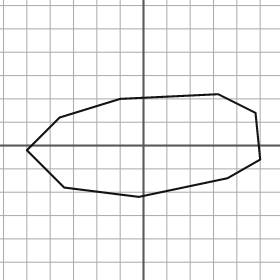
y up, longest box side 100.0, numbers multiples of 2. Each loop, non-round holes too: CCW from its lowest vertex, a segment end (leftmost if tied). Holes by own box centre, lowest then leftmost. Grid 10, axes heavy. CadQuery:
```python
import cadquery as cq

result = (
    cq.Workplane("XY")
    .moveTo(-2.0, -22.0)
    .lineTo(36.0, -14.0)
    .lineTo(50.0, -6.0)
    .lineTo(48.0, 14.0)
    .lineTo(32.0, 22.0)
    .lineTo(-10.0, 20.0)
    .lineTo(-36.0, 12.0)
    .lineTo(-50.0, -2.0)
    .lineTo(-34.0, -18.0)
    .close()
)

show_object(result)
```